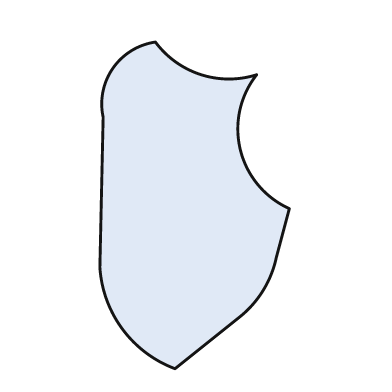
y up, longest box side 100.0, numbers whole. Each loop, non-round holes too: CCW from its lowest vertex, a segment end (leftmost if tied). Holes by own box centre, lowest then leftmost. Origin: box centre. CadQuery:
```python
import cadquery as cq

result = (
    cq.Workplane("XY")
    .moveTo(-6.0, -50.0)
    .lineTo(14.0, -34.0)
    .threePointArc((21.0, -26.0), (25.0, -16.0))
    .lineTo(29.0, -1.0)
    .threePointArc((14.0, 17.0), (19.0, 40.0))
    .threePointArc((2.0, 40.0), (-12.0, 50.0))
    .threePointArc((-25.0, 42.0), (-28.0, 27.0))
    .lineTo(-29.0, -19.0)
    .threePointArc((-22.0, -38.0), (-6.0, -50.0))
    .close()
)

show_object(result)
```